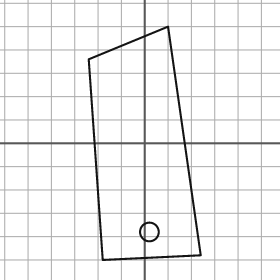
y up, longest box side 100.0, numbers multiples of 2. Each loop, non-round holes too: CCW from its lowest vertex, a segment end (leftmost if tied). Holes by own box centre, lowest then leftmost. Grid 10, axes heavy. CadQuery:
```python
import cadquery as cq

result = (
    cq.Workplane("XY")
    .moveTo(-18.0, -50.0)
    .lineTo(24.0, -48.0)
    .lineTo(10.0, 50.0)
    .lineTo(-24.0, 36.0)
    .close()
    .moveTo(2.0, -38.0)
    .circle(4.0)
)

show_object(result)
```